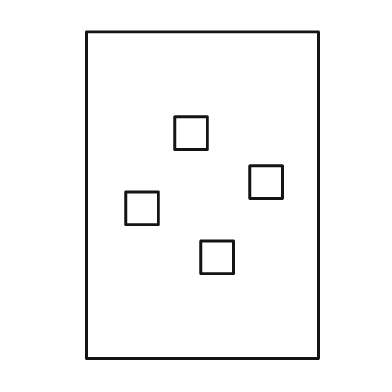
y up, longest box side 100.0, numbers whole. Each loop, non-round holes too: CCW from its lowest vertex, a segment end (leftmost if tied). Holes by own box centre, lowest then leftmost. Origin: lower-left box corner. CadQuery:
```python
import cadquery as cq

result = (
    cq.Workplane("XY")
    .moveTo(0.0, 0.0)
    .lineTo(71.0, 0.0)
    .lineTo(71.0, 100.0)
    .lineTo(0.0, 100.0)
    .close()
    .moveTo(35.0, 26.0)
    .lineTo(45.0, 26.0)
    .lineTo(45.0, 36.0)
    .lineTo(35.0, 36.0)
    .close()
    .moveTo(12.0, 41.0)
    .lineTo(22.0, 41.0)
    .lineTo(22.0, 51.0)
    .lineTo(12.0, 51.0)
    .close()
    .moveTo(50.0, 49.0)
    .lineTo(60.0, 49.0)
    .lineTo(60.0, 59.0)
    .lineTo(50.0, 59.0)
    .close()
    .moveTo(27.0, 64.0)
    .lineTo(37.0, 64.0)
    .lineTo(37.0, 74.0)
    .lineTo(27.0, 74.0)
    .close()
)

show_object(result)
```